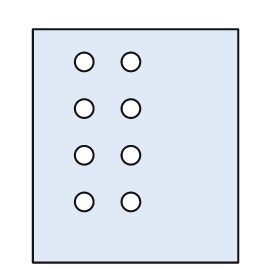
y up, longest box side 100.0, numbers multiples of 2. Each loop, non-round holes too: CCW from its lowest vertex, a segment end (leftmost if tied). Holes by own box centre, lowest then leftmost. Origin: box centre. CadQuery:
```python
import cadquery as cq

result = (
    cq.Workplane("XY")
    .moveTo(-44.0, -50.0)
    .lineTo(44.0, -50.0)
    .lineTo(44.0, 50.0)
    .lineTo(-44.0, 50.0)
    .close()
    .moveTo(-22.0, -24.0)
    .circle(4.0)
    .moveTo(-2.0, -24.0)
    .circle(4.0)
    .moveTo(-22.0, -4.0)
    .circle(4.0)
    .moveTo(-2.0, -4.0)
    .circle(4.0)
    .moveTo(-22.0, 16.0)
    .circle(4.0)
    .moveTo(-2.0, 16.0)
    .circle(4.0)
    .moveTo(-22.0, 36.0)
    .circle(4.0)
    .moveTo(-2.0, 36.0)
    .circle(4.0)
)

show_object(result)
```